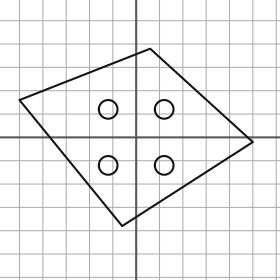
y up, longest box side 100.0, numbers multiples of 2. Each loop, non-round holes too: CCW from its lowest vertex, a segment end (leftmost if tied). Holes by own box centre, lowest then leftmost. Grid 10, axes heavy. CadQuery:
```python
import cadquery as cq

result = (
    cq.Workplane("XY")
    .moveTo(-6.0, -38.0)
    .lineTo(50.0, -2.0)
    .lineTo(6.0, 38.0)
    .lineTo(-50.0, 16.0)
    .close()
    .moveTo(-12.0, -12.0)
    .circle(4.0)
    .moveTo(12.0, -12.0)
    .circle(4.0)
    .moveTo(-12.0, 12.0)
    .circle(4.0)
    .moveTo(12.0, 12.0)
    .circle(4.0)
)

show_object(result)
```